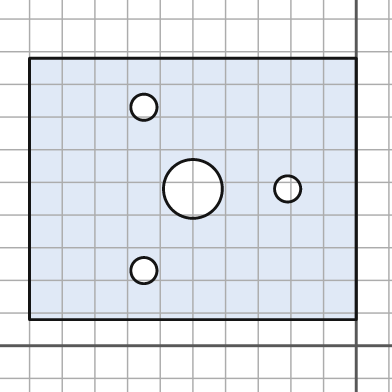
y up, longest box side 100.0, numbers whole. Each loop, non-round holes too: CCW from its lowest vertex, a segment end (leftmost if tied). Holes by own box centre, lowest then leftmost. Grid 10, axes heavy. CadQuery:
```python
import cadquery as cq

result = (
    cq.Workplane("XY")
    .moveTo(-100.0, 8.0)
    .lineTo(0.0, 8.0)
    .lineTo(0.0, 88.0)
    .lineTo(-100.0, 88.0)
    .close()
    .moveTo(-65.0, 23.0)
    .circle(4.0)
    .moveTo(-50.0, 48.0)
    .circle(9.0)
    .moveTo(-21.0, 48.0)
    .circle(4.0)
    .moveTo(-65.0, 73.0)
    .circle(4.0)
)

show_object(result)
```